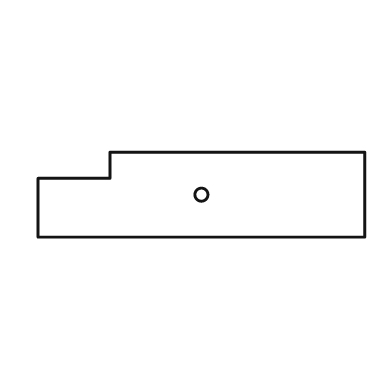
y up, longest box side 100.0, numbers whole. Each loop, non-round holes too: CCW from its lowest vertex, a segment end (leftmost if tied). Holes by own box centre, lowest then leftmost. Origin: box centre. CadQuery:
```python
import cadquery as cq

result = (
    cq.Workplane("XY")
    .moveTo(-50.0, -13.0)
    .lineTo(50.0, -13.0)
    .lineTo(50.0, 13.0)
    .lineTo(-28.0, 13.0)
    .lineTo(-28.0, 5.0)
    .lineTo(-50.0, 5.0)
    .close()
    .moveTo(0.0, 0.0)
    .circle(2.0)
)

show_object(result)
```